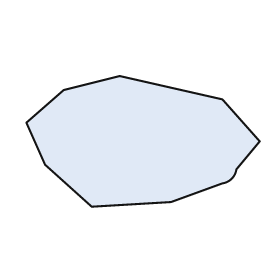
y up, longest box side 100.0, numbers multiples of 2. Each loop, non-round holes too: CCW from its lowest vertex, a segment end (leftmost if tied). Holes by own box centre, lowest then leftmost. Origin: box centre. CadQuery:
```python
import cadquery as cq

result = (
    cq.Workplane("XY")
    .moveTo(-22.0, -28.0)
    .lineTo(12.0, -26.0)
    .lineTo(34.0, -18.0)
    .threePointArc((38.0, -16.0), (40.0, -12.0))
    .lineTo(50.0, 0.0)
    .lineTo(34.0, 18.0)
    .lineTo(-10.0, 28.0)
    .lineTo(-34.0, 22.0)
    .lineTo(-50.0, 8.0)
    .lineTo(-42.0, -10.0)
    .close()
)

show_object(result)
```